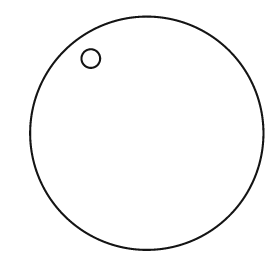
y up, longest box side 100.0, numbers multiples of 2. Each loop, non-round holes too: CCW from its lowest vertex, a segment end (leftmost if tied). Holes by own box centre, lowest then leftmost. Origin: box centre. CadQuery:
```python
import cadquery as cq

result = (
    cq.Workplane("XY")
    .moveTo(0.0, 0.0)
    .circle(50.0)
    .moveTo(-24.0, 32.0)
    .circle(4.0)
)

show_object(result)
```